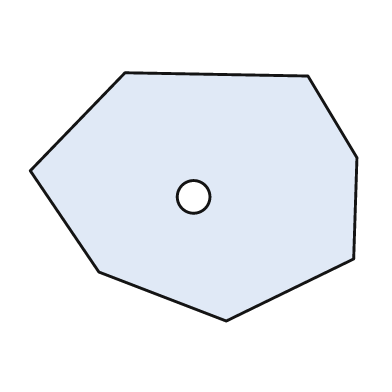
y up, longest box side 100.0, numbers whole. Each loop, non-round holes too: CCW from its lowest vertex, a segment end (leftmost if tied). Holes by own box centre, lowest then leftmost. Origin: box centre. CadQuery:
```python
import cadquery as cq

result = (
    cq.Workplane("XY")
    .moveTo(10.0, -38.0)
    .lineTo(49.0, -19.0)
    .lineTo(50.0, 12.0)
    .lineTo(35.0, 37.0)
    .lineTo(-21.0, 38.0)
    .lineTo(-50.0, 8.0)
    .lineTo(-29.0, -23.0)
    .close()
    .moveTo(0.0, 0.0)
    .circle(5.0)
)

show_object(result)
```